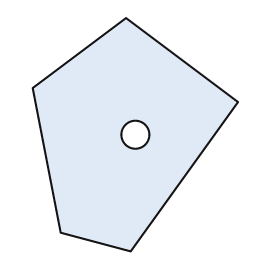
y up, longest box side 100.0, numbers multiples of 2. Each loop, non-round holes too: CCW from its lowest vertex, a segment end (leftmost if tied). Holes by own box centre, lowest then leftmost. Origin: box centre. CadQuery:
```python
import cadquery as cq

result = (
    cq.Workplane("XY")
    .moveTo(-2.0, -50.0)
    .lineTo(44.0, 14.0)
    .lineTo(-4.0, 50.0)
    .lineTo(-44.0, 20.0)
    .lineTo(-32.0, -42.0)
    .close()
    .moveTo(0.0, 0.0)
    .circle(6.0)
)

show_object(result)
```